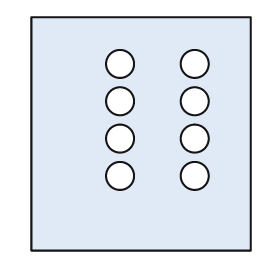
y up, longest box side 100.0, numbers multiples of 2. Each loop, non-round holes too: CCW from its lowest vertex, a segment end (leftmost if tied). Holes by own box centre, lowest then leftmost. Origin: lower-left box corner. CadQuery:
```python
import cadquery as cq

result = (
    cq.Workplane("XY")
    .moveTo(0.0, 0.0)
    .lineTo(94.0, 0.0)
    .lineTo(94.0, 100.0)
    .lineTo(0.0, 100.0)
    .close()
    .moveTo(38.0, 32.0)
    .circle(6.0)
    .moveTo(70.0, 32.0)
    .circle(6.0)
    .moveTo(38.0, 48.0)
    .circle(6.0)
    .moveTo(70.0, 48.0)
    .circle(6.0)
    .moveTo(38.0, 64.0)
    .circle(6.0)
    .moveTo(70.0, 64.0)
    .circle(6.0)
    .moveTo(38.0, 80.0)
    .circle(6.0)
    .moveTo(70.0, 80.0)
    .circle(6.0)
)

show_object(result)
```